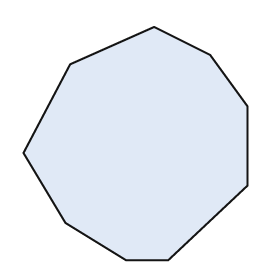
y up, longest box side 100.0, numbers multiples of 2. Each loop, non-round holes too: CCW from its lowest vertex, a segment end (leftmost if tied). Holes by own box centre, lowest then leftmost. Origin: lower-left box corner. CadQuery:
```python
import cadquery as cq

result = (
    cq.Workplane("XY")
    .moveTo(44.0, 0.0)
    .lineTo(62.0, 0.0)
    .lineTo(96.0, 32.0)
    .lineTo(96.0, 66.0)
    .lineTo(80.0, 88.0)
    .lineTo(56.0, 100.0)
    .lineTo(20.0, 84.0)
    .lineTo(0.0, 46.0)
    .lineTo(18.0, 16.0)
    .close()
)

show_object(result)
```